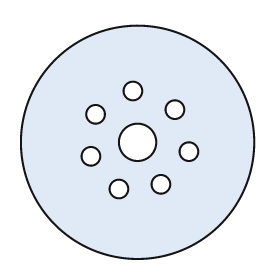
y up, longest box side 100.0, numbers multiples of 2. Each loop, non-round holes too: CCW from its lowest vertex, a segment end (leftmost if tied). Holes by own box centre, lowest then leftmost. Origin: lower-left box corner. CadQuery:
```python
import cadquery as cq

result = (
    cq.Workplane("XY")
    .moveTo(50.0, 50.0)
    .circle(50.0)
    .moveTo(42.0, 30.0)
    .circle(4.0)
    .moveTo(60.0, 32.0)
    .circle(4.0)
    .moveTo(30.0, 44.0)
    .circle(4.0)
    .moveTo(72.0, 46.0)
    .circle(4.0)
    .moveTo(50.0, 50.0)
    .circle(8.0)
    .moveTo(32.0, 62.0)
    .circle(4.0)
    .moveTo(66.0, 64.0)
    .circle(4.0)
    .moveTo(48.0, 72.0)
    .circle(4.0)
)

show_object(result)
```